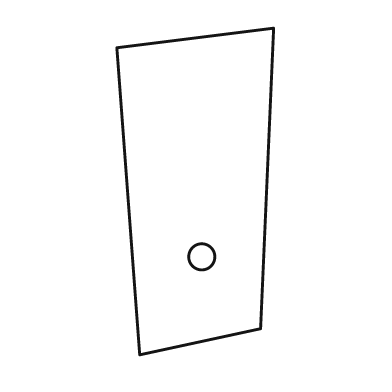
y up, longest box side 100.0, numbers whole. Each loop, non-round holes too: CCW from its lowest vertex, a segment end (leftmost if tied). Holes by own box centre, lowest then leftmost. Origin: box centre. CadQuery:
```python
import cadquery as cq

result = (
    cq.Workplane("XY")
    .moveTo(-17.0, -50.0)
    .lineTo(20.0, -42.0)
    .lineTo(24.0, 50.0)
    .lineTo(-24.0, 44.0)
    .close()
    .moveTo(2.0, -20.0)
    .circle(4.0)
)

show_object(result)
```